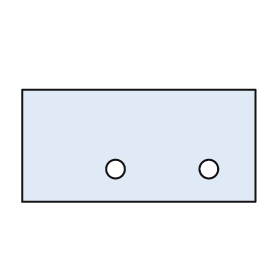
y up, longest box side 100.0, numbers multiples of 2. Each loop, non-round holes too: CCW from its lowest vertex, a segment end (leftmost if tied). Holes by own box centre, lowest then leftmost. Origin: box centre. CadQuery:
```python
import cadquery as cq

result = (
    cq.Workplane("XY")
    .moveTo(-50.0, -24.0)
    .lineTo(50.0, -24.0)
    .lineTo(50.0, 24.0)
    .lineTo(-50.0, 24.0)
    .close()
    .moveTo(-10.0, -10.0)
    .circle(4.0)
    .moveTo(30.0, -10.0)
    .circle(4.0)
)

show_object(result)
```